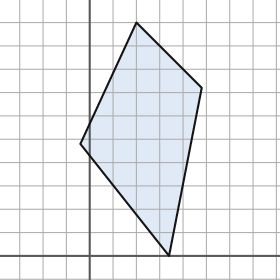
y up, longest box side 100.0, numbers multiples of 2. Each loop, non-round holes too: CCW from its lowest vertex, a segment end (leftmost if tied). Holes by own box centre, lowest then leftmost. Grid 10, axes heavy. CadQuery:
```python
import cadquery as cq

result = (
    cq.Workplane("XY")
    .moveTo(34.0, 0.0)
    .lineTo(48.0, 72.0)
    .lineTo(20.0, 100.0)
    .lineTo(-4.0, 48.0)
    .close()
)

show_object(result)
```